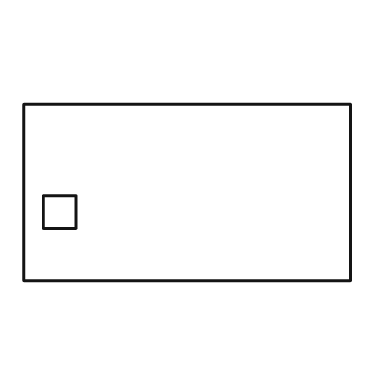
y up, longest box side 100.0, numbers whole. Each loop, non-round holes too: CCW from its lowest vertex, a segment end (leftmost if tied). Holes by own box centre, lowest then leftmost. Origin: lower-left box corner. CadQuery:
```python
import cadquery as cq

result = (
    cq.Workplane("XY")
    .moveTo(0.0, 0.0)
    .lineTo(100.0, 0.0)
    .lineTo(100.0, 54.0)
    .lineTo(0.0, 54.0)
    .close()
    .moveTo(6.0, 16.0)
    .lineTo(16.0, 16.0)
    .lineTo(16.0, 26.0)
    .lineTo(6.0, 26.0)
    .close()
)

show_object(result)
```